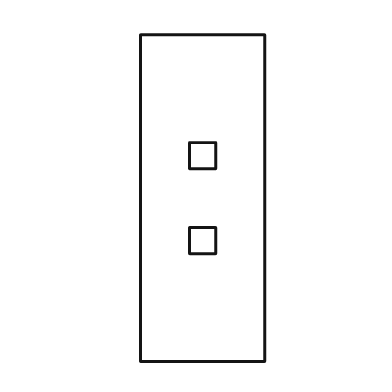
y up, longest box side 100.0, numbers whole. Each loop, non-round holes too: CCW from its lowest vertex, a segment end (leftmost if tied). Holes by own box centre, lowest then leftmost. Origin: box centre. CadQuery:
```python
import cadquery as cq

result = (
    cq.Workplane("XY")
    .moveTo(-19.0, -50.0)
    .lineTo(19.0, -50.0)
    .lineTo(19.0, 50.0)
    .lineTo(-19.0, 50.0)
    .close()
    .moveTo(-4.0, -17.0)
    .lineTo(4.0, -17.0)
    .lineTo(4.0, -9.0)
    .lineTo(-4.0, -9.0)
    .close()
    .moveTo(-4.0, 9.0)
    .lineTo(4.0, 9.0)
    .lineTo(4.0, 17.0)
    .lineTo(-4.0, 17.0)
    .close()
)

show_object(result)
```